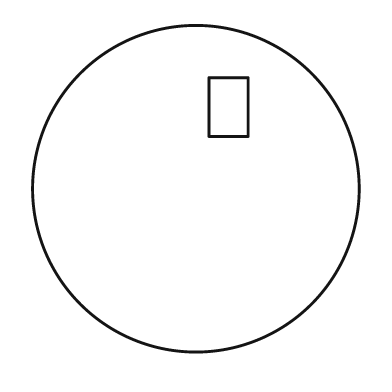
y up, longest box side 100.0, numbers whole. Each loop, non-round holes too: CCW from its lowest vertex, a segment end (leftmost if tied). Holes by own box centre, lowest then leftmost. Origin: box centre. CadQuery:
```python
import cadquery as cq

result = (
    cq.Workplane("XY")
    .moveTo(0.0, 0.0)
    .circle(50.0)
    .moveTo(4.0, 16.0)
    .lineTo(16.0, 16.0)
    .lineTo(16.0, 34.0)
    .lineTo(4.0, 34.0)
    .close()
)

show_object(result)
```